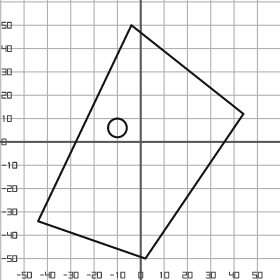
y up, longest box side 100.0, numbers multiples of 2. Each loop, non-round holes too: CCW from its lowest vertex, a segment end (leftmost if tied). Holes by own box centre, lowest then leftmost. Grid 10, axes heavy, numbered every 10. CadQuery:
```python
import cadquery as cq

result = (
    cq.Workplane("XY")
    .moveTo(2.0, -50.0)
    .lineTo(44.0, 12.0)
    .lineTo(-4.0, 50.0)
    .lineTo(-44.0, -34.0)
    .close()
    .moveTo(-10.0, 6.0)
    .circle(4.0)
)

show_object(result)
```